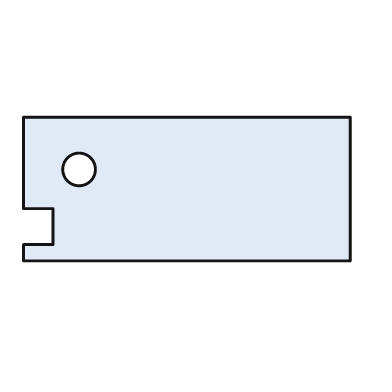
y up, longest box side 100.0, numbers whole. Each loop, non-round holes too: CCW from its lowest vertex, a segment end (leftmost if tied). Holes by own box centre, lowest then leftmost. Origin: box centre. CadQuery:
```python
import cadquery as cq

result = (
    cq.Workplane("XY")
    .moveTo(-50.0, -22.0)
    .lineTo(50.0, -22.0)
    .lineTo(50.0, 22.0)
    .lineTo(-50.0, 22.0)
    .lineTo(-50.0, -6.0)
    .lineTo(-41.0, -6.0)
    .lineTo(-41.0, -17.0)
    .lineTo(-50.0, -17.0)
    .close()
    .moveTo(-33.0, 6.0)
    .circle(5.0)
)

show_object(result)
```